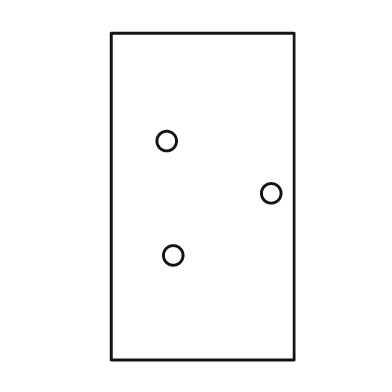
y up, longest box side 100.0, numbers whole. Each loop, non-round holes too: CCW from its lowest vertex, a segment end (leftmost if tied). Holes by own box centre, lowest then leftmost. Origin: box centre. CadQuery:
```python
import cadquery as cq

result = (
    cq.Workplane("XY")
    .moveTo(-28.0, -50.0)
    .lineTo(28.0, -50.0)
    .lineTo(28.0, 50.0)
    .lineTo(-28.0, 50.0)
    .close()
    .moveTo(-9.0, -18.0)
    .circle(3.0)
    .moveTo(21.0, 1.0)
    .circle(3.0)
    .moveTo(-11.0, 17.0)
    .circle(3.0)
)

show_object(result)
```